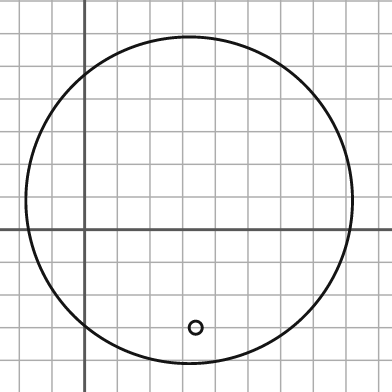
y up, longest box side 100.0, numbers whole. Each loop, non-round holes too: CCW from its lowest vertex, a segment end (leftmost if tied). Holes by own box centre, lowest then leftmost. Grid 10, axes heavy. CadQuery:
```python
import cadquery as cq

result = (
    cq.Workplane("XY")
    .moveTo(32.0, 9.0)
    .circle(50.0)
    .moveTo(34.0, -30.0)
    .circle(2.0)
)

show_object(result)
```